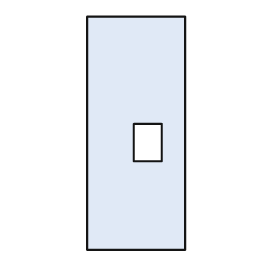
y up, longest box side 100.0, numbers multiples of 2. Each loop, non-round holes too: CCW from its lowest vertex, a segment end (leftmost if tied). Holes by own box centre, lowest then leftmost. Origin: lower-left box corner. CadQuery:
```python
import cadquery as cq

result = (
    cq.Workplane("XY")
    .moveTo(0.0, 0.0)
    .lineTo(42.0, 0.0)
    .lineTo(42.0, 100.0)
    .lineTo(0.0, 100.0)
    .close()
    .moveTo(20.0, 38.0)
    .lineTo(32.0, 38.0)
    .lineTo(32.0, 54.0)
    .lineTo(20.0, 54.0)
    .close()
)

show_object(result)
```